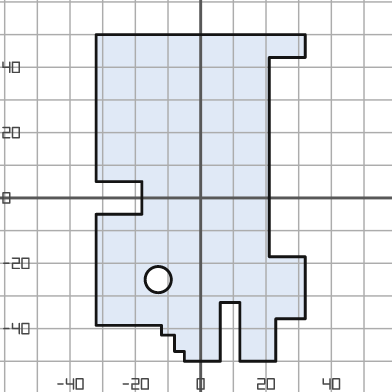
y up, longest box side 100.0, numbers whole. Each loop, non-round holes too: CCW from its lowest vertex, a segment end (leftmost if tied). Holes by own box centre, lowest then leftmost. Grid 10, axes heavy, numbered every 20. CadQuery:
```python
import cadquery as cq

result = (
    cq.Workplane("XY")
    .moveTo(-5.0, -50.0)
    .lineTo(6.0, -50.0)
    .lineTo(6.0, -32.0)
    .lineTo(12.0, -32.0)
    .lineTo(12.0, -50.0)
    .lineTo(23.0, -50.0)
    .lineTo(23.0, -37.0)
    .lineTo(32.0, -37.0)
    .lineTo(32.0, -18.0)
    .lineTo(21.0, -18.0)
    .lineTo(21.0, 43.0)
    .lineTo(32.0, 43.0)
    .lineTo(32.0, 50.0)
    .lineTo(-32.0, 50.0)
    .lineTo(-32.0, 5.0)
    .lineTo(-18.0, 5.0)
    .lineTo(-18.0, -5.0)
    .lineTo(-32.0, -5.0)
    .lineTo(-32.0, -39.0)
    .lineTo(-12.0, -39.0)
    .lineTo(-12.0, -42.0)
    .lineTo(-8.0, -42.0)
    .lineTo(-8.0, -47.0)
    .lineTo(-5.0, -47.0)
    .close()
    .moveTo(-13.0, -25.0)
    .circle(4.0)
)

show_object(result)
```